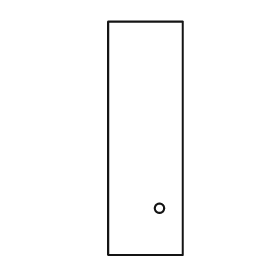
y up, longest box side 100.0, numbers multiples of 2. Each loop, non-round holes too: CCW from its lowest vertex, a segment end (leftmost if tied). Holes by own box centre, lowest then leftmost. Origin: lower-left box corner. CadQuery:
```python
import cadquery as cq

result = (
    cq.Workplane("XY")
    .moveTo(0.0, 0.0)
    .lineTo(32.0, 0.0)
    .lineTo(32.0, 100.0)
    .lineTo(0.0, 100.0)
    .close()
    .moveTo(22.0, 20.0)
    .circle(2.0)
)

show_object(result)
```